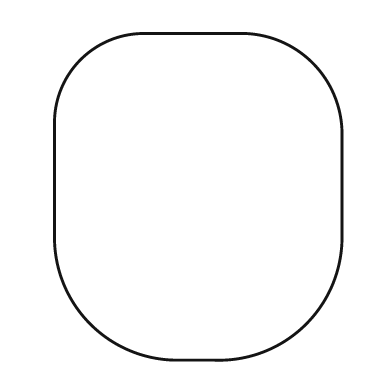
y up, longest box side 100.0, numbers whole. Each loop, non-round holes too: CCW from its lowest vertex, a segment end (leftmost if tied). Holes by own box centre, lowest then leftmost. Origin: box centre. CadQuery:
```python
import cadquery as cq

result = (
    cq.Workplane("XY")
    .moveTo(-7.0, -50.0)
    .lineTo(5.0, -50.0)
    .threePointArc((33.0, -39.0), (44.0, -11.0))
    .lineTo(44.0, 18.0)
    .threePointArc((35.0, 41.0), (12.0, 50.0))
    .lineTo(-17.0, 50.0)
    .threePointArc((-36.0, 42.0), (-44.0, 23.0))
    .lineTo(-44.0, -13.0)
    .threePointArc((-33.0, -39.0), (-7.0, -50.0))
    .close()
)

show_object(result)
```